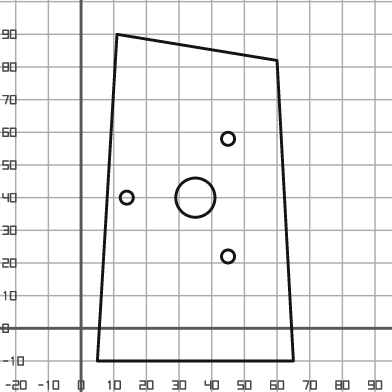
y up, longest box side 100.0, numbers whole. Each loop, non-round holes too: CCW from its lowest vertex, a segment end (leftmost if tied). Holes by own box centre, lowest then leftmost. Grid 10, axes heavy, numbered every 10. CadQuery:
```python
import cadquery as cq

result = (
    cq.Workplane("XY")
    .moveTo(5.0, -10.0)
    .lineTo(65.0, -10.0)
    .lineTo(60.0, 82.0)
    .lineTo(11.0, 90.0)
    .close()
    .moveTo(45.0, 22.0)
    .circle(2.0)
    .moveTo(14.0, 40.0)
    .circle(2.0)
    .moveTo(35.0, 40.0)
    .circle(6.0)
    .moveTo(45.0, 58.0)
    .circle(2.0)
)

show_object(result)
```